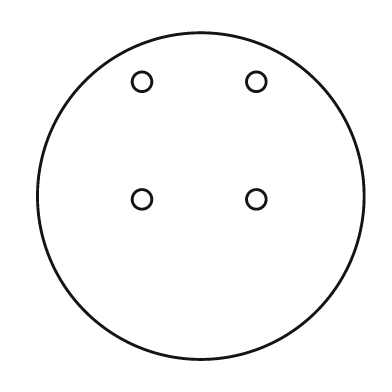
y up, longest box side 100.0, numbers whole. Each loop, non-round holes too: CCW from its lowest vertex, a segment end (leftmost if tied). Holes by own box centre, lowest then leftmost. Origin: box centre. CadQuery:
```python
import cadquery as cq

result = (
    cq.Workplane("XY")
    .moveTo(0.0, 0.0)
    .circle(50.0)
    .moveTo(-18.0, -1.0)
    .circle(3.0)
    .moveTo(17.0, -1.0)
    .circle(3.0)
    .moveTo(-18.0, 35.0)
    .circle(3.0)
    .moveTo(17.0, 35.0)
    .circle(3.0)
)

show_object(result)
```